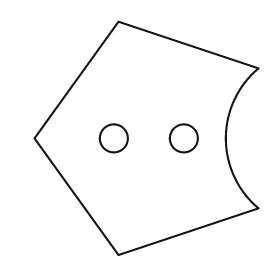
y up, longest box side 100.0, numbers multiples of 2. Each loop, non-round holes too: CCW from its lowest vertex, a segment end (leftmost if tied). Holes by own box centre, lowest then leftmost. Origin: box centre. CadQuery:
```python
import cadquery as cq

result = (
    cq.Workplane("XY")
    .moveTo(-12.0, -50.0)
    .lineTo(48.0, -30.0)
    .threePointArc((34.0, 0.0), (48.0, 30.0))
    .lineTo(-12.0, 50.0)
    .lineTo(-48.0, 0.0)
    .close()
    .moveTo(-14.0, 0.0)
    .circle(6.0)
    .moveTo(16.0, 0.0)
    .circle(6.0)
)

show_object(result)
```